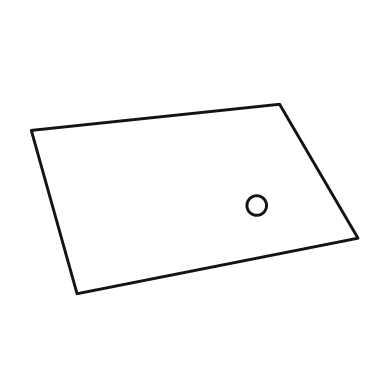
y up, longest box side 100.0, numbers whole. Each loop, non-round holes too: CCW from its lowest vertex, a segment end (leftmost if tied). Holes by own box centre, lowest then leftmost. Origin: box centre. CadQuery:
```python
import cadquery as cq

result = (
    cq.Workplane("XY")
    .moveTo(-36.0, -29.0)
    .lineTo(50.0, -12.0)
    .lineTo(26.0, 29.0)
    .lineTo(-50.0, 21.0)
    .close()
    .moveTo(19.0, -2.0)
    .circle(3.0)
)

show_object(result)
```